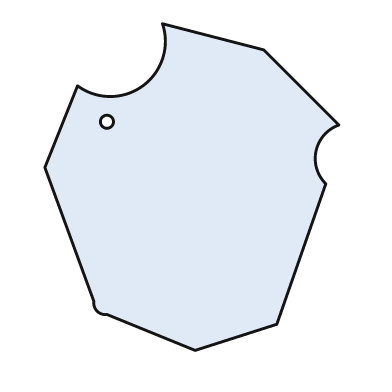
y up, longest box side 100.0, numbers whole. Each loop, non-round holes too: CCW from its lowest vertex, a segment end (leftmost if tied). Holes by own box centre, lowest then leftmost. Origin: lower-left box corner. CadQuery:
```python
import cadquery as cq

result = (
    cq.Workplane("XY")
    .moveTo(46.0, 0.0)
    .lineTo(71.0, 8.0)
    .lineTo(86.0, 51.0)
    .threePointArc((83.0, 61.0), (90.0, 69.0))
    .lineTo(67.0, 92.0)
    .lineTo(36.0, 100.0)
    .threePointArc((30.0, 81.0), (10.0, 81.0))
    .lineTo(0.0, 56.0)
    .lineTo(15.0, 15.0)
    .threePointArc((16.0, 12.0), (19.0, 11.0))
    .close()
    .moveTo(19.0, 70.0)
    .circle(2.0)
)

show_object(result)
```